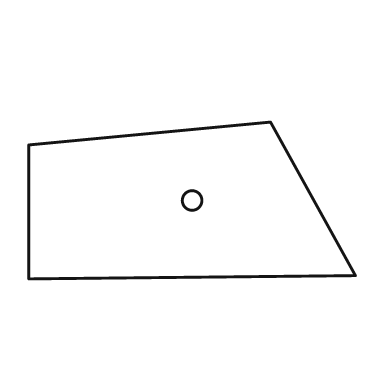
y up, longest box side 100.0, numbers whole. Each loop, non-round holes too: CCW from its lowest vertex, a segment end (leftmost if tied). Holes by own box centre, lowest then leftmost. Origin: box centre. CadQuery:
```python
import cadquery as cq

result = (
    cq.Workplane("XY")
    .moveTo(-50.0, -24.0)
    .lineTo(50.0, -23.0)
    .lineTo(24.0, 24.0)
    .lineTo(-50.0, 17.0)
    .close()
    .moveTo(0.0, 0.0)
    .circle(3.0)
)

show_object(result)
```